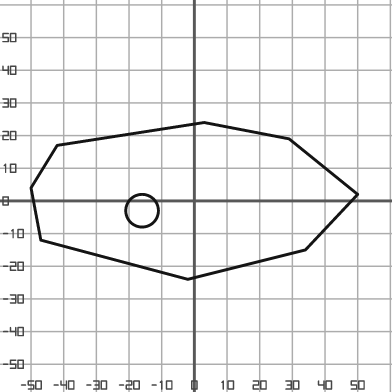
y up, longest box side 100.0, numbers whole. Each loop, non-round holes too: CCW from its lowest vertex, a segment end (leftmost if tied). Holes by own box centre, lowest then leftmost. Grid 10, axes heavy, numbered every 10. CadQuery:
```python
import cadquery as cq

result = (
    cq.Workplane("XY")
    .moveTo(-2.0, -24.0)
    .lineTo(34.0, -15.0)
    .lineTo(50.0, 2.0)
    .lineTo(29.0, 19.0)
    .lineTo(3.0, 24.0)
    .lineTo(-42.0, 17.0)
    .lineTo(-50.0, 4.0)
    .lineTo(-47.0, -12.0)
    .close()
    .moveTo(-16.0, -3.0)
    .circle(5.0)
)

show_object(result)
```